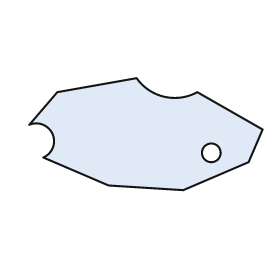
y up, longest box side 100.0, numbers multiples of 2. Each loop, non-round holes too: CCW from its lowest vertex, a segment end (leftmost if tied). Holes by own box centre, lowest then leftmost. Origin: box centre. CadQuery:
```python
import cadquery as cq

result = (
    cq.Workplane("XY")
    .moveTo(16.0, -24.0)
    .lineTo(44.0, -12.0)
    .lineTo(50.0, 2.0)
    .lineTo(22.0, 18.0)
    .threePointArc((8.0, 16.0), (-4.0, 24.0))
    .lineTo(-38.0, 18.0)
    .lineTo(-50.0, 4.0)
    .threePointArc((-40.0, 0.0), (-44.0, -10.0))
    .lineTo(-16.0, -22.0)
    .close()
    .moveTo(28.0, -8.0)
    .circle(4.0)
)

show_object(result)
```